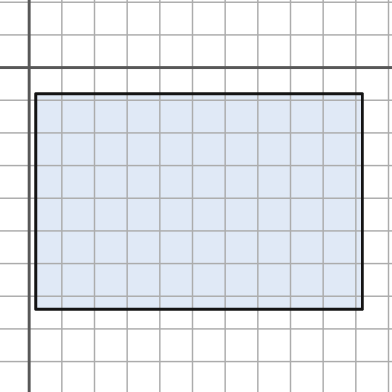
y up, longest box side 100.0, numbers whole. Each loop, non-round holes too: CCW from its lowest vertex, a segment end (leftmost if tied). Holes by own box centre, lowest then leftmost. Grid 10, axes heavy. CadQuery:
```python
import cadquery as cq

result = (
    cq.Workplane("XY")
    .moveTo(2.0, -74.0)
    .lineTo(102.0, -74.0)
    .lineTo(102.0, -8.0)
    .lineTo(2.0, -8.0)
    .close()
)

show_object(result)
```